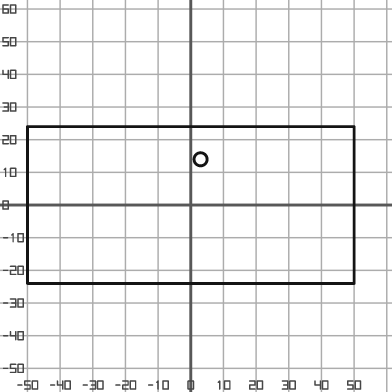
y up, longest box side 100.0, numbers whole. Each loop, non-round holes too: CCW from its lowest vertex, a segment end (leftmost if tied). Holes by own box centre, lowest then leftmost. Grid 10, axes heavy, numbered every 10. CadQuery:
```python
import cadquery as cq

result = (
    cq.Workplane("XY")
    .moveTo(-50.0, -24.0)
    .lineTo(50.0, -24.0)
    .lineTo(50.0, 24.0)
    .lineTo(-50.0, 24.0)
    .close()
    .moveTo(3.0, 14.0)
    .circle(2.0)
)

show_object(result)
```